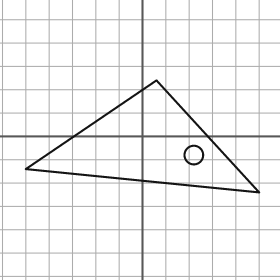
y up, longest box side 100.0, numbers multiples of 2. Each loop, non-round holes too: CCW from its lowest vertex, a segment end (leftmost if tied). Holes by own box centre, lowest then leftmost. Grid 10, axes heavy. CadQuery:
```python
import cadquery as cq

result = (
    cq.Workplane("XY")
    .moveTo(50.0, -24.0)
    .lineTo(6.0, 24.0)
    .lineTo(-50.0, -14.0)
    .close()
    .moveTo(22.0, -8.0)
    .circle(4.0)
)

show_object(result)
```